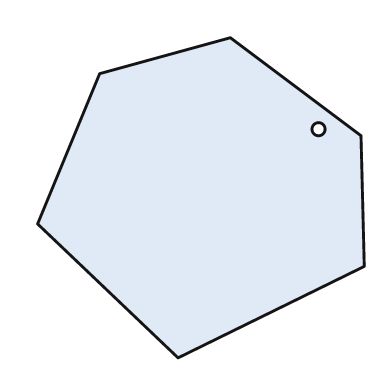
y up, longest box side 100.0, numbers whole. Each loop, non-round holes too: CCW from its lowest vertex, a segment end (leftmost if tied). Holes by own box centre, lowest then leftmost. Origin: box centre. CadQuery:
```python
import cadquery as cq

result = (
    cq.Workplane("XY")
    .moveTo(-7.0, -49.0)
    .lineTo(50.0, -21.0)
    .lineTo(49.0, 19.0)
    .lineTo(9.0, 49.0)
    .lineTo(-31.0, 38.0)
    .lineTo(-50.0, -8.0)
    .close()
    .moveTo(36.0, 21.0)
    .circle(2.0)
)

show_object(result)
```